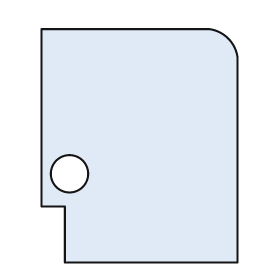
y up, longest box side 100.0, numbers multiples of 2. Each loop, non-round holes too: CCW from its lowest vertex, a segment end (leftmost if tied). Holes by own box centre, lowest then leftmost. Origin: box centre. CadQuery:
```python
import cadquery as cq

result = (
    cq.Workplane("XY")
    .moveTo(-32.0, -50.0)
    .lineTo(42.0, -50.0)
    .lineTo(42.0, 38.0)
    .threePointArc((38.0, 46.0), (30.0, 50.0))
    .lineTo(-42.0, 50.0)
    .lineTo(-42.0, -26.0)
    .lineTo(-32.0, -26.0)
    .close()
    .moveTo(-30.0, -12.0)
    .circle(8.0)
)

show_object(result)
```